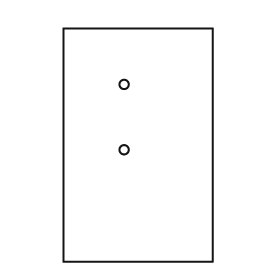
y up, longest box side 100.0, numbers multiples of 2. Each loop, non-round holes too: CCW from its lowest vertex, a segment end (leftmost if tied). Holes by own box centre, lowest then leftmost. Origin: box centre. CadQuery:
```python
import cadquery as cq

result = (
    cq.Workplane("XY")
    .moveTo(-32.0, -50.0)
    .lineTo(32.0, -50.0)
    .lineTo(32.0, 50.0)
    .lineTo(-32.0, 50.0)
    .close()
    .moveTo(-6.0, -2.0)
    .circle(2.0)
    .moveTo(-6.0, 26.0)
    .circle(2.0)
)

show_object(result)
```